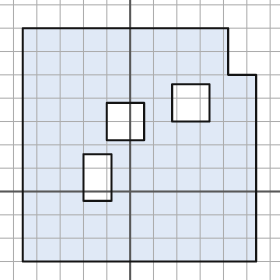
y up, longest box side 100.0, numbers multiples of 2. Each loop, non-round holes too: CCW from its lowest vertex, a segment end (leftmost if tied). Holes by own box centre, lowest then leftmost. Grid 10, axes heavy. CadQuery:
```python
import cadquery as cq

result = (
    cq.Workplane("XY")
    .moveTo(-46.0, -30.0)
    .lineTo(54.0, -30.0)
    .lineTo(54.0, 50.0)
    .lineTo(42.0, 50.0)
    .lineTo(42.0, 70.0)
    .lineTo(-46.0, 70.0)
    .close()
    .moveTo(-20.0, -4.0)
    .lineTo(-8.0, -4.0)
    .lineTo(-8.0, 16.0)
    .lineTo(-20.0, 16.0)
    .close()
    .moveTo(-10.0, 22.0)
    .lineTo(6.0, 22.0)
    .lineTo(6.0, 38.0)
    .lineTo(-10.0, 38.0)
    .close()
    .moveTo(18.0, 30.0)
    .lineTo(34.0, 30.0)
    .lineTo(34.0, 46.0)
    .lineTo(18.0, 46.0)
    .close()
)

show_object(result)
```